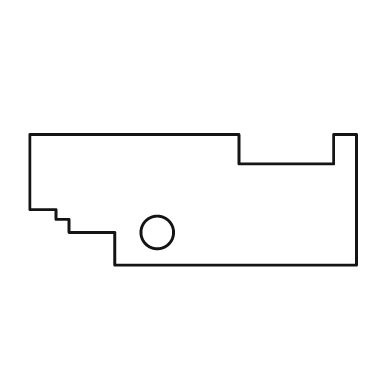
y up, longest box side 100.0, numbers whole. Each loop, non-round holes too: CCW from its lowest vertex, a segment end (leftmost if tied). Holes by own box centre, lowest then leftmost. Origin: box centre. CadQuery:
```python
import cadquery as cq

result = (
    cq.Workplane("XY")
    .moveTo(-24.0, -20.0)
    .lineTo(50.0, -20.0)
    .lineTo(50.0, 20.0)
    .lineTo(43.0, 20.0)
    .lineTo(43.0, 11.0)
    .lineTo(14.0, 11.0)
    .lineTo(14.0, 20.0)
    .lineTo(-50.0, 20.0)
    .lineTo(-50.0, -3.0)
    .lineTo(-42.0, -3.0)
    .lineTo(-42.0, -6.0)
    .lineTo(-38.0, -6.0)
    .lineTo(-38.0, -10.0)
    .lineTo(-24.0, -10.0)
    .close()
    .moveTo(-11.0, -10.0)
    .circle(5.0)
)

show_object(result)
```